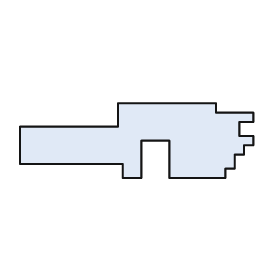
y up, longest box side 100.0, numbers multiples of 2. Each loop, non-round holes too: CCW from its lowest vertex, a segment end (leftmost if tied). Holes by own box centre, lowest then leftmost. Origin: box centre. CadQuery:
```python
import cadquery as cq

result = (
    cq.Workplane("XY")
    .moveTo(-6.0, -16.0)
    .lineTo(2.0, -16.0)
    .lineTo(2.0, 0.0)
    .lineTo(14.0, 0.0)
    .lineTo(14.0, -16.0)
    .lineTo(38.0, -16.0)
    .lineTo(38.0, -12.0)
    .lineTo(42.0, -12.0)
    .lineTo(42.0, -6.0)
    .lineTo(46.0, -6.0)
    .lineTo(46.0, -2.0)
    .lineTo(50.0, -2.0)
    .lineTo(50.0, 2.0)
    .lineTo(44.0, 2.0)
    .lineTo(44.0, 8.0)
    .lineTo(50.0, 8.0)
    .lineTo(50.0, 12.0)
    .lineTo(34.0, 12.0)
    .lineTo(34.0, 16.0)
    .lineTo(-8.0, 16.0)
    .lineTo(-8.0, 6.0)
    .lineTo(-50.0, 6.0)
    .lineTo(-50.0, -10.0)
    .lineTo(-6.0, -10.0)
    .close()
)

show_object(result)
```